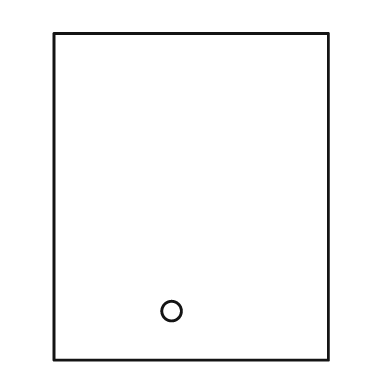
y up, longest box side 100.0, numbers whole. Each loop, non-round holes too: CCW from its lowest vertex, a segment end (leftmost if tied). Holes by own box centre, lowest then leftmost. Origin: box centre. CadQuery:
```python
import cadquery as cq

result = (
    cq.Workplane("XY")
    .moveTo(-42.0, -50.0)
    .lineTo(42.0, -50.0)
    .lineTo(42.0, 50.0)
    .lineTo(-42.0, 50.0)
    .close()
    .moveTo(-6.0, -35.0)
    .circle(3.0)
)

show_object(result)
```